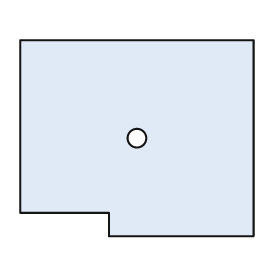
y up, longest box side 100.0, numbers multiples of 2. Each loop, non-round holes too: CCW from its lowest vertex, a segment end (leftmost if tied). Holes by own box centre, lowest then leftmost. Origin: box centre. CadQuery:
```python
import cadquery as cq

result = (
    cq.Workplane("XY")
    .moveTo(-12.0, -42.0)
    .lineTo(50.0, -42.0)
    .lineTo(50.0, 42.0)
    .lineTo(-50.0, 42.0)
    .lineTo(-50.0, -32.0)
    .lineTo(-12.0, -32.0)
    .close()
    .moveTo(0.0, 0.0)
    .circle(4.0)
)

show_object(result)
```